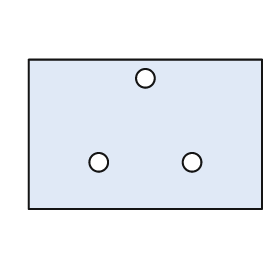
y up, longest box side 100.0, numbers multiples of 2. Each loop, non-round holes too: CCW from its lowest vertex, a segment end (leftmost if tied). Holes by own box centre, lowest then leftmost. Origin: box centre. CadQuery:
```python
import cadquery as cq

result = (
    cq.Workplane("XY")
    .moveTo(-50.0, -32.0)
    .lineTo(50.0, -32.0)
    .lineTo(50.0, 32.0)
    .lineTo(-50.0, 32.0)
    .close()
    .moveTo(-20.0, -12.0)
    .circle(4.0)
    .moveTo(20.0, -12.0)
    .circle(4.0)
    .moveTo(0.0, 24.0)
    .circle(4.0)
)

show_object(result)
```